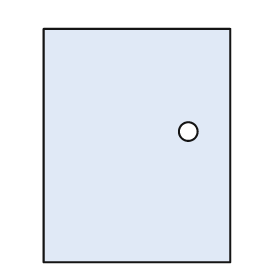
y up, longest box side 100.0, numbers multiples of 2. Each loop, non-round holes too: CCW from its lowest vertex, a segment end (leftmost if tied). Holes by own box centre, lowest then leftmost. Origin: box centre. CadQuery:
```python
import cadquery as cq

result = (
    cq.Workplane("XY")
    .moveTo(-40.0, -50.0)
    .lineTo(40.0, -50.0)
    .lineTo(40.0, 50.0)
    .lineTo(-40.0, 50.0)
    .close()
    .moveTo(22.0, 6.0)
    .circle(4.0)
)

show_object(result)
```